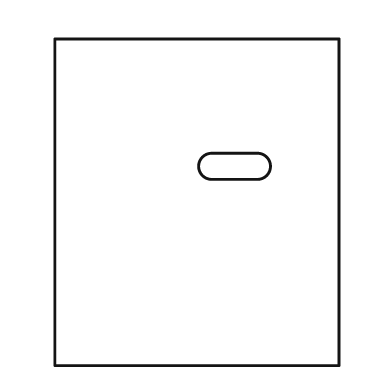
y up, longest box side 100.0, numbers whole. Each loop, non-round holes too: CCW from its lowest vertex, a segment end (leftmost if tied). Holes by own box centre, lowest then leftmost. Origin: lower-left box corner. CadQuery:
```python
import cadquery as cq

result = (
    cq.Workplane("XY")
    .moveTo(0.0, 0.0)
    .lineTo(87.0, 0.0)
    .lineTo(87.0, 100.0)
    .lineTo(0.0, 100.0)
    .close()
    .moveTo(48.0, 57.0)
    .lineTo(62.0, 57.0)
    .threePointArc((66.0, 61.0), (62.0, 65.0))
    .lineTo(48.0, 65.0)
    .threePointArc((44.0, 61.0), (48.0, 57.0))
    .close()
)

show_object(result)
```